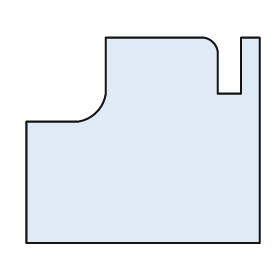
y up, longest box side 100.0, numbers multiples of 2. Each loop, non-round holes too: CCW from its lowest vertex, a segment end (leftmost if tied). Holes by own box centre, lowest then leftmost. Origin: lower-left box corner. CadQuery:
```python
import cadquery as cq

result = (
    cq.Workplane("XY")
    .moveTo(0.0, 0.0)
    .lineTo(100.0, 0.0)
    .lineTo(100.0, 88.0)
    .lineTo(92.0, 88.0)
    .lineTo(92.0, 64.0)
    .lineTo(82.0, 64.0)
    .lineTo(82.0, 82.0)
    .threePointArc((80.0, 86.0), (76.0, 88.0))
    .lineTo(34.0, 88.0)
    .lineTo(34.0, 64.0)
    .threePointArc((30.0, 56.0), (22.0, 52.0))
    .lineTo(0.0, 52.0)
    .close()
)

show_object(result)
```